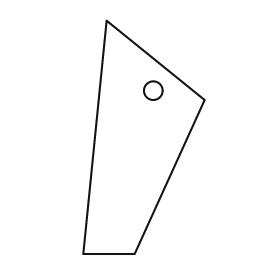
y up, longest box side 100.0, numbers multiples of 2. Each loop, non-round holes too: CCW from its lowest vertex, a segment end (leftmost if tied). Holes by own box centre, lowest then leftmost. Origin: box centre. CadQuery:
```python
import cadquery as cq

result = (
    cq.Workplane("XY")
    .moveTo(-26.0, -50.0)
    .lineTo(-4.0, -50.0)
    .lineTo(26.0, 16.0)
    .lineTo(-16.0, 50.0)
    .close()
    .moveTo(4.0, 20.0)
    .circle(4.0)
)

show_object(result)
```